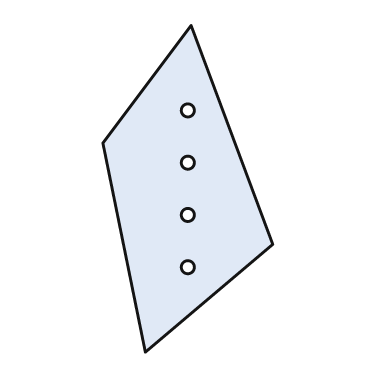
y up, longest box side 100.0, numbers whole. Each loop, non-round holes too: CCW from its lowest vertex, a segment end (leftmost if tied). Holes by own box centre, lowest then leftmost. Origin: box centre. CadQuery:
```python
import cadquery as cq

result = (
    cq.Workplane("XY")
    .moveTo(-13.0, -50.0)
    .lineTo(26.0, -17.0)
    .lineTo(1.0, 50.0)
    .lineTo(-26.0, 14.0)
    .close()
    .moveTo(0.0, -24.0)
    .circle(2.0)
    .moveTo(0.0, -8.0)
    .circle(2.0)
    .moveTo(0.0, 8.0)
    .circle(2.0)
    .moveTo(0.0, 24.0)
    .circle(2.0)
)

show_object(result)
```